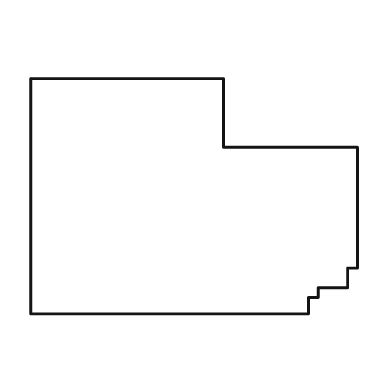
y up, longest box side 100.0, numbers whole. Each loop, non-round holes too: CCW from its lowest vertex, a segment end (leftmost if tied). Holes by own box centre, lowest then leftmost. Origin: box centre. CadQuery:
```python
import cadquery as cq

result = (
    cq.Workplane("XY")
    .moveTo(-50.0, -36.0)
    .lineTo(35.0, -36.0)
    .lineTo(35.0, -31.0)
    .lineTo(38.0, -31.0)
    .lineTo(38.0, -28.0)
    .lineTo(47.0, -28.0)
    .lineTo(47.0, -22.0)
    .lineTo(50.0, -22.0)
    .lineTo(50.0, 15.0)
    .lineTo(9.0, 15.0)
    .lineTo(9.0, 36.0)
    .lineTo(-50.0, 36.0)
    .close()
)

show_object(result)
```